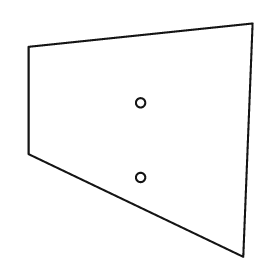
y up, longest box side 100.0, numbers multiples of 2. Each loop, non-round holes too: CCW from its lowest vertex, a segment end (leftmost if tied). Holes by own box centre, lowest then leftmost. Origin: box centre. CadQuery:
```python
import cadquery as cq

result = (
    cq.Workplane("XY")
    .moveTo(44.0, -50.0)
    .lineTo(48.0, 50.0)
    .lineTo(-48.0, 40.0)
    .lineTo(-48.0, -6.0)
    .close()
    .moveTo(0.0, -16.0)
    .circle(2.0)
    .moveTo(0.0, 16.0)
    .circle(2.0)
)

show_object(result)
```